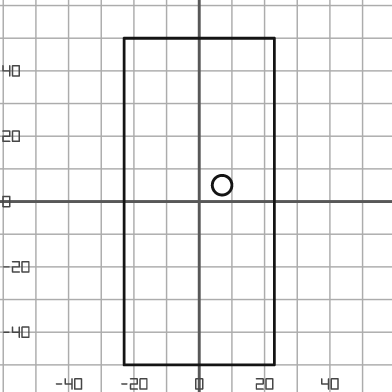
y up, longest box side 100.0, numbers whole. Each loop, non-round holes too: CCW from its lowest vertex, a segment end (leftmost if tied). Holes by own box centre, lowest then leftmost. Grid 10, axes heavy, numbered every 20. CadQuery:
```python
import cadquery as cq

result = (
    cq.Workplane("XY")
    .moveTo(-23.0, -50.0)
    .lineTo(23.0, -50.0)
    .lineTo(23.0, 50.0)
    .lineTo(-23.0, 50.0)
    .close()
    .moveTo(7.0, 5.0)
    .circle(3.0)
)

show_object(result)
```